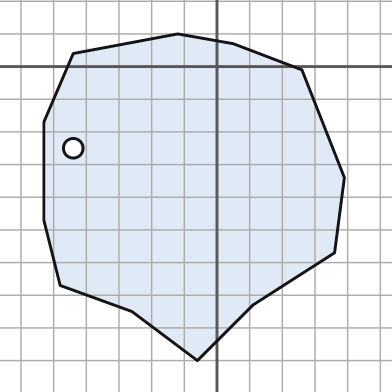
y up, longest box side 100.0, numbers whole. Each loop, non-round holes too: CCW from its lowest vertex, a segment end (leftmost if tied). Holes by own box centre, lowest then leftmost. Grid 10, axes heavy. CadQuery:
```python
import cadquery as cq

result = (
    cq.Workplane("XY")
    .moveTo(-6.0, -90.0)
    .lineTo(11.0, -73.0)
    .lineTo(36.0, -57.0)
    .lineTo(39.0, -34.0)
    .lineTo(26.0, -1.0)
    .lineTo(5.0, 7.0)
    .lineTo(-12.0, 10.0)
    .lineTo(-44.0, 4.0)
    .lineTo(-53.0, -17.0)
    .lineTo(-53.0, -47.0)
    .lineTo(-48.0, -67.0)
    .lineTo(-26.0, -75.0)
    .close()
    .moveTo(-44.0, -25.0)
    .circle(3.0)
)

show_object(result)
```